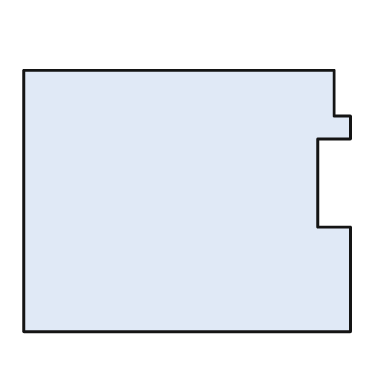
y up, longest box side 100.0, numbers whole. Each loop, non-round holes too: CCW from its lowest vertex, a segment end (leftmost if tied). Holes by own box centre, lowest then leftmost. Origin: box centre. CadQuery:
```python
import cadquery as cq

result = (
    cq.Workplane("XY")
    .moveTo(-50.0, -40.0)
    .lineTo(50.0, -40.0)
    .lineTo(50.0, -8.0)
    .lineTo(40.0, -8.0)
    .lineTo(40.0, 19.0)
    .lineTo(50.0, 19.0)
    .lineTo(50.0, 26.0)
    .lineTo(45.0, 26.0)
    .lineTo(45.0, 40.0)
    .lineTo(-50.0, 40.0)
    .close()
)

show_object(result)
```